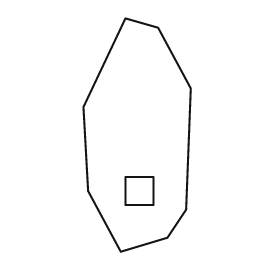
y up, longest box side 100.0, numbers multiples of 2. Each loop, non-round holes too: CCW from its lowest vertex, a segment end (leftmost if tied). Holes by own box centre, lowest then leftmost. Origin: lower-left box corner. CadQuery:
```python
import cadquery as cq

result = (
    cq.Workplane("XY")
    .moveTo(16.0, 0.0)
    .lineTo(36.0, 6.0)
    .lineTo(44.0, 18.0)
    .lineTo(46.0, 70.0)
    .lineTo(32.0, 96.0)
    .lineTo(18.0, 100.0)
    .lineTo(0.0, 62.0)
    .lineTo(2.0, 26.0)
    .close()
    .moveTo(18.0, 20.0)
    .lineTo(30.0, 20.0)
    .lineTo(30.0, 32.0)
    .lineTo(18.0, 32.0)
    .close()
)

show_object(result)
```